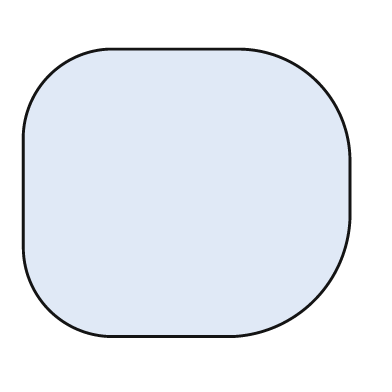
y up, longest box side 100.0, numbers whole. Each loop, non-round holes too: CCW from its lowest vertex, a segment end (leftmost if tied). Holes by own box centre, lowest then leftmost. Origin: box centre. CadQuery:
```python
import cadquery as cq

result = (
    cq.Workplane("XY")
    .moveTo(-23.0, -44.0)
    .lineTo(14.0, -44.0)
    .threePointArc((39.0, -33.0), (50.0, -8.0))
    .lineTo(50.0, 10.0)
    .threePointArc((40.0, 34.0), (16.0, 44.0))
    .lineTo(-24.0, 44.0)
    .threePointArc((-42.0, 36.0), (-50.0, 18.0))
    .lineTo(-50.0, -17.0)
    .threePointArc((-42.0, -36.0), (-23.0, -44.0))
    .close()
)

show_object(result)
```